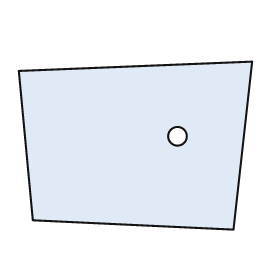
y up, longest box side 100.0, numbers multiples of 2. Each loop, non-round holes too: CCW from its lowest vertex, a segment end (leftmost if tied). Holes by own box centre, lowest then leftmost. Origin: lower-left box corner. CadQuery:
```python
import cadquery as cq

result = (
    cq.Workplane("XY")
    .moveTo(92.0, 0.0)
    .lineTo(100.0, 72.0)
    .lineTo(0.0, 68.0)
    .lineTo(6.0, 4.0)
    .close()
    .moveTo(68.0, 40.0)
    .circle(4.0)
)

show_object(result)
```